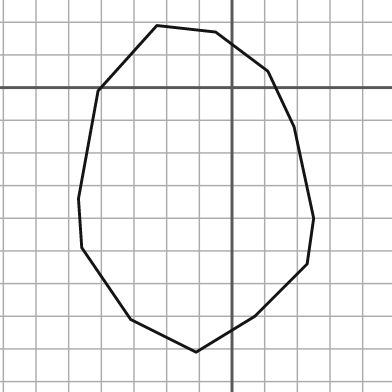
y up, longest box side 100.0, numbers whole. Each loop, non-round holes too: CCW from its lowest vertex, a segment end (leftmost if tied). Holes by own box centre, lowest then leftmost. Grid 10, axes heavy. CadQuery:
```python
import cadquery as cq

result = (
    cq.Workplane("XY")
    .moveTo(-11.0, -81.0)
    .lineTo(7.0, -70.0)
    .lineTo(23.0, -54.0)
    .lineTo(25.0, -40.0)
    .lineTo(19.0, -12.0)
    .lineTo(11.0, 5.0)
    .lineTo(-5.0, 17.0)
    .lineTo(-23.0, 19.0)
    .lineTo(-41.0, -1.0)
    .lineTo(-47.0, -34.0)
    .lineTo(-46.0, -49.0)
    .lineTo(-31.0, -71.0)
    .close()
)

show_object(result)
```